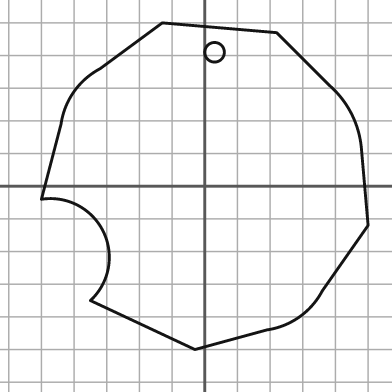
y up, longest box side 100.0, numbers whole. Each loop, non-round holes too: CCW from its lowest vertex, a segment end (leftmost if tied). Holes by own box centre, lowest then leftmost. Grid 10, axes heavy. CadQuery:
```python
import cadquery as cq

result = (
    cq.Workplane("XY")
    .moveTo(-3.0, -50.0)
    .lineTo(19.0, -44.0)
    .threePointArc((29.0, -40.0), (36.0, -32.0))
    .lineTo(50.0, -12.0)
    .lineTo(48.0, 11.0)
    .threePointArc((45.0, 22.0), (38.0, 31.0))
    .lineTo(22.0, 47.0)
    .lineTo(-13.0, 50.0)
    .lineTo(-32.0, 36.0)
    .threePointArc((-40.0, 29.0), (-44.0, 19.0))
    .lineTo(-50.0, -4.0)
    .threePointArc((-31.0, -14.0), (-35.0, -35.0))
    .close()
    .moveTo(3.0, 41.0)
    .circle(3.0)
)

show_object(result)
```